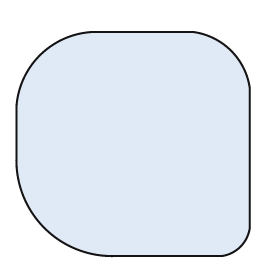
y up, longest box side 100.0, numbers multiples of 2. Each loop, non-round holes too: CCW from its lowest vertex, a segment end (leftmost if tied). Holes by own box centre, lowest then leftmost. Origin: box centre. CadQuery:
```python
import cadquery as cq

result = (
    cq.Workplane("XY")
    .moveTo(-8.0, -48.0)
    .lineTo(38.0, -48.0)
    .threePointArc((46.0, -44.0), (50.0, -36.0))
    .lineTo(50.0, 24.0)
    .threePointArc((42.0, 40.0), (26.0, 48.0))
    .lineTo(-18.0, 48.0)
    .threePointArc((-40.0, 38.0), (-50.0, 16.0))
    .lineTo(-50.0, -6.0)
    .threePointArc((-38.0, -36.0), (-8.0, -48.0))
    .close()
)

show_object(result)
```